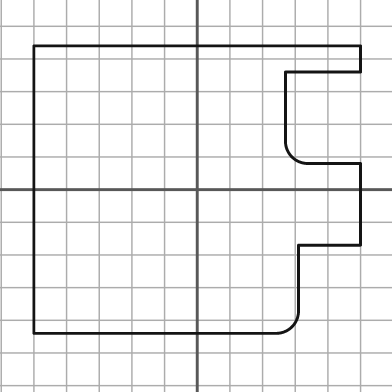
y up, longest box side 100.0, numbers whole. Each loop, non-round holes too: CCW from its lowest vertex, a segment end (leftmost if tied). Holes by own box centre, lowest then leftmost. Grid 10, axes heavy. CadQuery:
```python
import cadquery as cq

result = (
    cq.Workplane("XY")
    .moveTo(-50.0, -44.0)
    .lineTo(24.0, -44.0)
    .threePointArc((29.0, -42.0), (31.0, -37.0))
    .lineTo(31.0, -17.0)
    .lineTo(50.0, -17.0)
    .lineTo(50.0, 8.0)
    .lineTo(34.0, 8.0)
    .threePointArc((29.0, 10.0), (27.0, 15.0))
    .lineTo(27.0, 36.0)
    .lineTo(50.0, 36.0)
    .lineTo(50.0, 44.0)
    .lineTo(-50.0, 44.0)
    .close()
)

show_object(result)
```